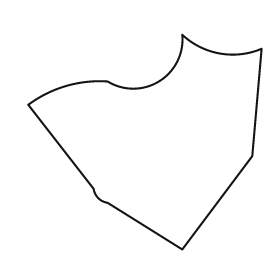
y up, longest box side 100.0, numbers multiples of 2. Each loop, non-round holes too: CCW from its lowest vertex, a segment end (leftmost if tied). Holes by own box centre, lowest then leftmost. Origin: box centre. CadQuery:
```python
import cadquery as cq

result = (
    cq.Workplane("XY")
    .moveTo(16.0, -46.0)
    .lineTo(46.0, -6.0)
    .lineTo(50.0, 40.0)
    .threePointArc((32.0, 38.0), (16.0, 46.0))
    .threePointArc((6.0, 26.0), (-16.0, 26.0))
    .threePointArc((-34.0, 24.0), (-50.0, 16.0))
    .lineTo(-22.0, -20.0)
    .threePointArc((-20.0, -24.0), (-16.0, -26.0))
    .close()
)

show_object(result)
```